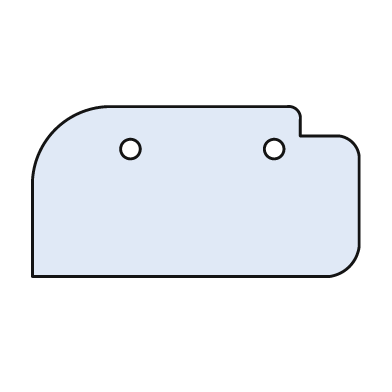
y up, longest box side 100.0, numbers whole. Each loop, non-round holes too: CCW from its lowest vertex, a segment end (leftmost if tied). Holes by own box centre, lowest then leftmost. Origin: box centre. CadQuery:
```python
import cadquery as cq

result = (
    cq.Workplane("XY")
    .moveTo(-50.0, -26.0)
    .lineTo(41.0, -26.0)
    .threePointArc((47.0, -23.0), (50.0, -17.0))
    .lineTo(50.0, 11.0)
    .threePointArc((48.0, 15.0), (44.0, 17.0))
    .lineTo(32.0, 17.0)
    .lineTo(32.0, 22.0)
    .threePointArc((31.0, 25.0), (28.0, 26.0))
    .lineTo(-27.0, 26.0)
    .threePointArc((-43.0, 19.0), (-50.0, 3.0))
    .close()
    .moveTo(-20.0, 13.0)
    .circle(3.0)
    .moveTo(24.0, 13.0)
    .circle(3.0)
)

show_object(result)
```